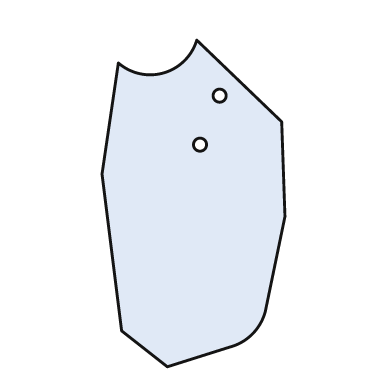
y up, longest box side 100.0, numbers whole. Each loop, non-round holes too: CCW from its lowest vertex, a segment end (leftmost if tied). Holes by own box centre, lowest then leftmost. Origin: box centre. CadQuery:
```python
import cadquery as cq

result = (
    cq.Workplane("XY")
    .moveTo(-8.0, -50.0)
    .lineTo(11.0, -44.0)
    .threePointArc((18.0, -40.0), (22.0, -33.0))
    .lineTo(28.0, -4.0)
    .lineTo(27.0, 25.0)
    .lineTo(1.0, 50.0)
    .threePointArc((-9.0, 40.0), (-23.0, 43.0))
    .lineTo(-28.0, 9.0)
    .lineTo(-22.0, -39.0)
    .close()
    .moveTo(2.0, 18.0)
    .circle(2.0)
    .moveTo(8.0, 33.0)
    .circle(2.0)
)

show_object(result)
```